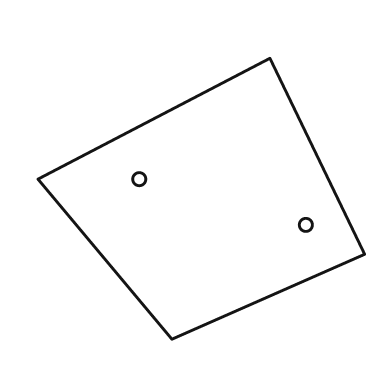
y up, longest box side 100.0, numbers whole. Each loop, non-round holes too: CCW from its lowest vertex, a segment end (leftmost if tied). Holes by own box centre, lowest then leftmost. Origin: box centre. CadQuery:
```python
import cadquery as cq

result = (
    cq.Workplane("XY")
    .moveTo(-9.0, -43.0)
    .lineTo(50.0, -17.0)
    .lineTo(21.0, 43.0)
    .lineTo(-50.0, 6.0)
    .close()
    .moveTo(32.0, -8.0)
    .circle(2.0)
    .moveTo(-19.0, 6.0)
    .circle(2.0)
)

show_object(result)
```